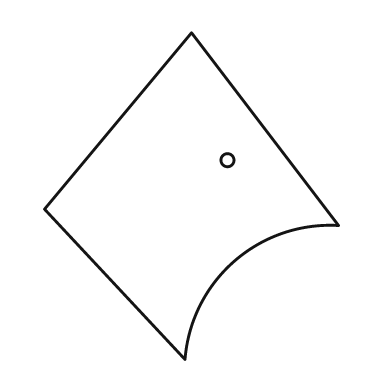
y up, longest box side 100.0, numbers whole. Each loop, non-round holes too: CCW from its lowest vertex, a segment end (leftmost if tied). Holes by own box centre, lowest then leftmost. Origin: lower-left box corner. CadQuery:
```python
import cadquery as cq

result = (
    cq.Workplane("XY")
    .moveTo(43.0, 0.0)
    .threePointArc((58.0, 30.0), (90.0, 41.0))
    .lineTo(45.0, 100.0)
    .lineTo(0.0, 46.0)
    .close()
    .moveTo(56.0, 61.0)
    .circle(2.0)
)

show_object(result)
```